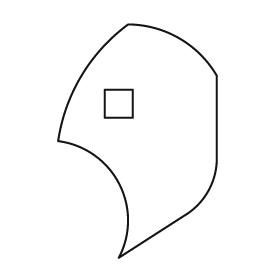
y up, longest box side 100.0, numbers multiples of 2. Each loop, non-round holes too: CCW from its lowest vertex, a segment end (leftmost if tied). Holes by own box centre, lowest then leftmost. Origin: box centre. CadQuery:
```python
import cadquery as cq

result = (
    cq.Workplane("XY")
    .moveTo(-8.0, -50.0)
    .lineTo(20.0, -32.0)
    .threePointArc((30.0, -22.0), (34.0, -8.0))
    .lineTo(34.0, 28.0)
    .threePointArc((18.0, 44.0), (-4.0, 50.0))
    .threePointArc((-24.0, 28.0), (-34.0, 0.0))
    .threePointArc((-8.0, -18.0), (-8.0, -50.0))
    .close()
    .moveTo(-14.0, 10.0)
    .lineTo(-2.0, 10.0)
    .lineTo(-2.0, 22.0)
    .lineTo(-14.0, 22.0)
    .close()
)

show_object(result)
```